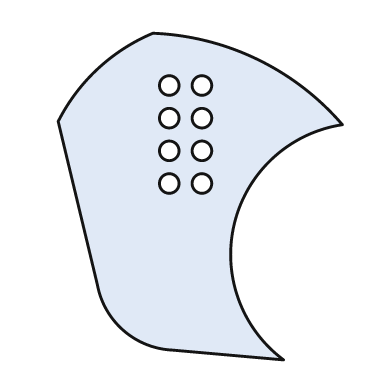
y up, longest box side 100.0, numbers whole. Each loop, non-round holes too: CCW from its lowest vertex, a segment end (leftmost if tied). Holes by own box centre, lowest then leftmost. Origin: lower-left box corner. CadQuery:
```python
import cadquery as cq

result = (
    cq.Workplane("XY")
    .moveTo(69.0, 0.0)
    .threePointArc((54.0, 42.0), (87.0, 72.0))
    .threePointArc((61.0, 92.0), (29.0, 100.0))
    .threePointArc((12.0, 89.0), (0.0, 73.0))
    .lineTo(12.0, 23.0)
    .threePointArc((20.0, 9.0), (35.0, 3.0))
    .close()
    .moveTo(34.0, 54.0)
    .circle(3.0)
    .moveTo(44.0, 54.0)
    .circle(3.0)
    .moveTo(34.0, 64.0)
    .circle(3.0)
    .moveTo(44.0, 64.0)
    .circle(3.0)
    .moveTo(34.0, 74.0)
    .circle(3.0)
    .moveTo(44.0, 74.0)
    .circle(3.0)
    .moveTo(34.0, 84.0)
    .circle(3.0)
    .moveTo(44.0, 84.0)
    .circle(3.0)
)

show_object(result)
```